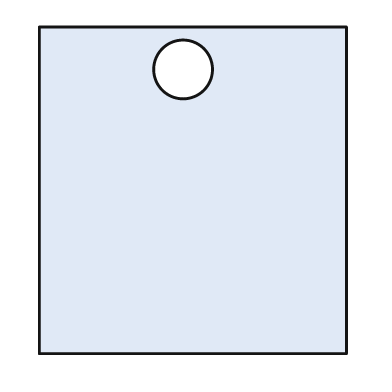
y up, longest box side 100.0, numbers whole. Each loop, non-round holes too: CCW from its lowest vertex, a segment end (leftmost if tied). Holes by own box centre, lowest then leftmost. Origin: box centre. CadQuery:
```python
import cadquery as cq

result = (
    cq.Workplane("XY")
    .moveTo(-47.0, -50.0)
    .lineTo(47.0, -50.0)
    .lineTo(47.0, 50.0)
    .lineTo(-47.0, 50.0)
    .close()
    .moveTo(-3.0, 37.0)
    .circle(9.0)
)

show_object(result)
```